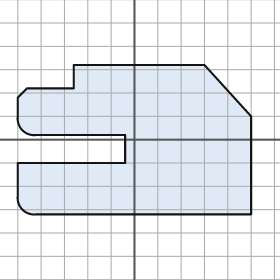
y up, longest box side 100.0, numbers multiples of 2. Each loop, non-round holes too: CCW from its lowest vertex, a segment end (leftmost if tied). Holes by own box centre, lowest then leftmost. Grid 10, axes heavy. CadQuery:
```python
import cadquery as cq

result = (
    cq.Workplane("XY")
    .moveTo(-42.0, -32.0)
    .lineTo(50.0, -32.0)
    .lineTo(50.0, 10.0)
    .lineTo(30.0, 32.0)
    .lineTo(-26.0, 32.0)
    .lineTo(-26.0, 22.0)
    .lineTo(-46.0, 22.0)
    .lineTo(-50.0, 18.0)
    .lineTo(-50.0, 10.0)
    .threePointArc((-48.0, 4.0), (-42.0, 2.0))
    .lineTo(-4.0, 2.0)
    .lineTo(-4.0, -10.0)
    .lineTo(-50.0, -10.0)
    .lineTo(-50.0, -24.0)
    .threePointArc((-48.0, -30.0), (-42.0, -32.0))
    .close()
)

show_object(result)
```